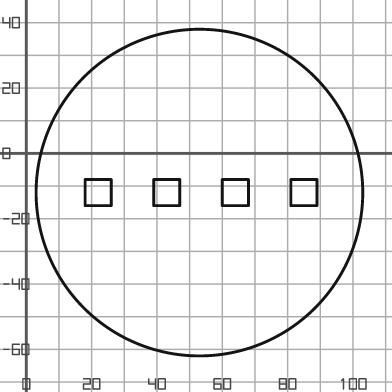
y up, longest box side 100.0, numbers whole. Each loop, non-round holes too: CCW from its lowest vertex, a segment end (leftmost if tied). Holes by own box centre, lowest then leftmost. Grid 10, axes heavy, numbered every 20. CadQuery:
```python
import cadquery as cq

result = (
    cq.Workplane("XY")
    .moveTo(53.0, -12.0)
    .circle(50.0)
    .moveTo(18.0, -16.0)
    .lineTo(26.0, -16.0)
    .lineTo(26.0, -8.0)
    .lineTo(18.0, -8.0)
    .close()
    .moveTo(39.0, -16.0)
    .lineTo(47.0, -16.0)
    .lineTo(47.0, -8.0)
    .lineTo(39.0, -8.0)
    .close()
    .moveTo(60.0, -16.0)
    .lineTo(68.0, -16.0)
    .lineTo(68.0, -8.0)
    .lineTo(60.0, -8.0)
    .close()
    .moveTo(81.0, -16.0)
    .lineTo(89.0, -16.0)
    .lineTo(89.0, -8.0)
    .lineTo(81.0, -8.0)
    .close()
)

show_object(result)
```